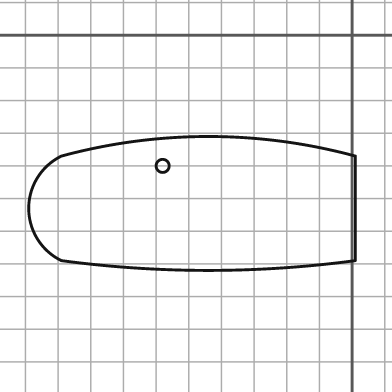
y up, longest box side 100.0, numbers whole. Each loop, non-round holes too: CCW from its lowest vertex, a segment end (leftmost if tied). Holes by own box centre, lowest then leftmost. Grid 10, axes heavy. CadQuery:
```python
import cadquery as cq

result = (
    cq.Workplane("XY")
    .moveTo(-89.0, -69.0)
    .threePointArc((-44.0, -72.0), (1.0, -69.0))
    .lineTo(1.0, -37.0)
    .threePointArc((-44.0, -31.0), (-89.0, -37.0))
    .threePointArc((-99.0, -53.0), (-89.0, -69.0))
    .close()
    .moveTo(-58.0, -40.0)
    .circle(2.0)
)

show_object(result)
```